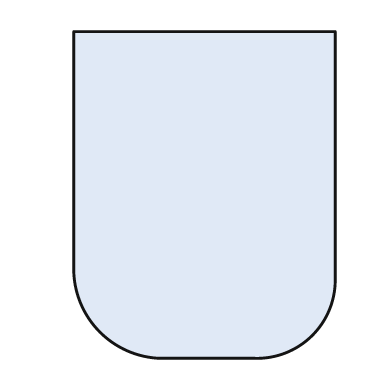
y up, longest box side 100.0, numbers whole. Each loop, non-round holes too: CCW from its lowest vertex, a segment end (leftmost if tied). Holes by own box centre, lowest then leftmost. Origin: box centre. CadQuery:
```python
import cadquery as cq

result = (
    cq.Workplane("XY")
    .moveTo(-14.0, -50.0)
    .lineTo(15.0, -50.0)
    .threePointArc((33.0, -43.0), (40.0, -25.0))
    .lineTo(40.0, 50.0)
    .lineTo(-40.0, 50.0)
    .lineTo(-40.0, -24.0)
    .threePointArc((-32.0, -42.0), (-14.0, -50.0))
    .close()
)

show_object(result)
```